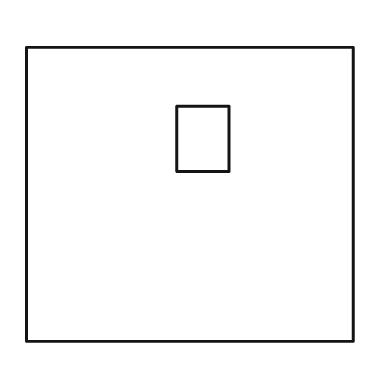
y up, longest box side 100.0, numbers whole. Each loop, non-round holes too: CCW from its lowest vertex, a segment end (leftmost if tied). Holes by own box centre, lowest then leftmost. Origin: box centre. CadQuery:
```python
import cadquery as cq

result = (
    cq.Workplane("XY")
    .moveTo(-50.0, -45.0)
    .lineTo(50.0, -45.0)
    .lineTo(50.0, 45.0)
    .lineTo(-50.0, 45.0)
    .close()
    .moveTo(-4.0, 7.0)
    .lineTo(12.0, 7.0)
    .lineTo(12.0, 27.0)
    .lineTo(-4.0, 27.0)
    .close()
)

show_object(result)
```